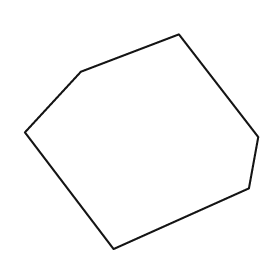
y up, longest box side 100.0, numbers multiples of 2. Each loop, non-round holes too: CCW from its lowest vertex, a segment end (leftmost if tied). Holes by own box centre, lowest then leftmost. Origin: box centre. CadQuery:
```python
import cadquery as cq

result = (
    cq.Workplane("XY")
    .moveTo(-12.0, -46.0)
    .lineTo(46.0, -20.0)
    .lineTo(50.0, 2.0)
    .lineTo(16.0, 46.0)
    .lineTo(-26.0, 30.0)
    .lineTo(-50.0, 4.0)
    .close()
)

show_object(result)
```